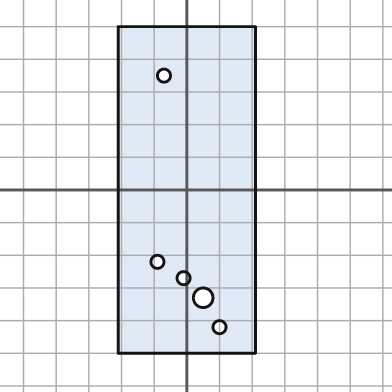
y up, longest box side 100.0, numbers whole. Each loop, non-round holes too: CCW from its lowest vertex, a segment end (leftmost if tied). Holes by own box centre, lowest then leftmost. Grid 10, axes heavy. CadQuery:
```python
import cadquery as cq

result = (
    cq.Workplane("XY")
    .moveTo(-21.0, -50.0)
    .lineTo(21.0, -50.0)
    .lineTo(21.0, 50.0)
    .lineTo(-21.0, 50.0)
    .close()
    .moveTo(10.0, -42.0)
    .circle(2.0)
    .moveTo(5.0, -33.0)
    .circle(3.0)
    .moveTo(-1.0, -27.0)
    .circle(2.0)
    .moveTo(-9.0, -22.0)
    .circle(2.0)
    .moveTo(-7.0, 35.0)
    .circle(2.0)
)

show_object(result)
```